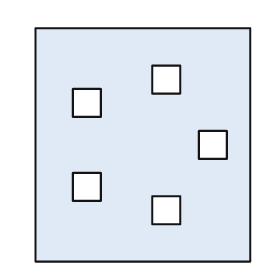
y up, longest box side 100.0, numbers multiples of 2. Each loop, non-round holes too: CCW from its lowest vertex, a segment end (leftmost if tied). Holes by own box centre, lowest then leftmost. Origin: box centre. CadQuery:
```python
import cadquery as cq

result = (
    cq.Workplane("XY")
    .moveTo(-46.0, -50.0)
    .lineTo(46.0, -50.0)
    .lineTo(46.0, 50.0)
    .lineTo(-46.0, 50.0)
    .close()
    .moveTo(4.0, -34.0)
    .lineTo(16.0, -34.0)
    .lineTo(16.0, -22.0)
    .lineTo(4.0, -22.0)
    .close()
    .moveTo(-30.0, -24.0)
    .lineTo(-18.0, -24.0)
    .lineTo(-18.0, -12.0)
    .lineTo(-30.0, -12.0)
    .close()
    .moveTo(24.0, -6.0)
    .lineTo(36.0, -6.0)
    .lineTo(36.0, 6.0)
    .lineTo(24.0, 6.0)
    .close()
    .moveTo(-30.0, 12.0)
    .lineTo(-18.0, 12.0)
    .lineTo(-18.0, 24.0)
    .lineTo(-30.0, 24.0)
    .close()
    .moveTo(4.0, 22.0)
    .lineTo(16.0, 22.0)
    .lineTo(16.0, 34.0)
    .lineTo(4.0, 34.0)
    .close()
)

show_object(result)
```